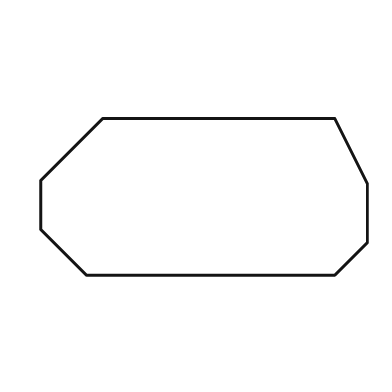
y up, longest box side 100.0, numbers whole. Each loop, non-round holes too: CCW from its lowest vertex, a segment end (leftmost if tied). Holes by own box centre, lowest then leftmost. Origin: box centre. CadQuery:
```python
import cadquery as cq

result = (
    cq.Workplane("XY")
    .moveTo(-36.0, -24.0)
    .lineTo(40.0, -24.0)
    .lineTo(50.0, -14.0)
    .lineTo(50.0, 4.0)
    .lineTo(40.0, 24.0)
    .lineTo(-31.0, 24.0)
    .lineTo(-50.0, 5.0)
    .lineTo(-50.0, -10.0)
    .close()
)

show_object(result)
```